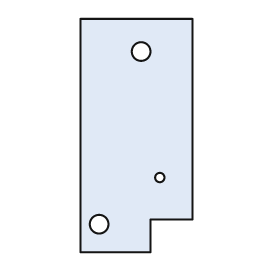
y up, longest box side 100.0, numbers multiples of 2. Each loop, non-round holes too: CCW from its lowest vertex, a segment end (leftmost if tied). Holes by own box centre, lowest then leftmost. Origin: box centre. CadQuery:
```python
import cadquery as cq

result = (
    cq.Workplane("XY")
    .moveTo(-24.0, -50.0)
    .lineTo(6.0, -50.0)
    .lineTo(6.0, -36.0)
    .lineTo(24.0, -36.0)
    .lineTo(24.0, 50.0)
    .lineTo(-24.0, 50.0)
    .close()
    .moveTo(-16.0, -38.0)
    .circle(4.0)
    .moveTo(10.0, -18.0)
    .circle(2.0)
    .moveTo(2.0, 36.0)
    .circle(4.0)
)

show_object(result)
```